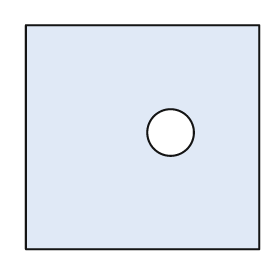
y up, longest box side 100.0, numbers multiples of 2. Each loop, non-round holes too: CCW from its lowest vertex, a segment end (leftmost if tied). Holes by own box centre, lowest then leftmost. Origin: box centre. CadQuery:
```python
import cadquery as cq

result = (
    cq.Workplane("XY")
    .moveTo(-50.0, -48.0)
    .lineTo(50.0, -48.0)
    .lineTo(50.0, 48.0)
    .lineTo(-50.0, 48.0)
    .close()
    .moveTo(12.0, 2.0)
    .circle(10.0)
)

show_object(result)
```